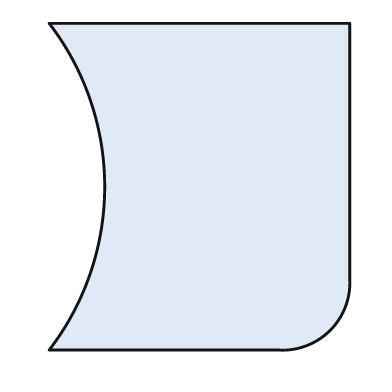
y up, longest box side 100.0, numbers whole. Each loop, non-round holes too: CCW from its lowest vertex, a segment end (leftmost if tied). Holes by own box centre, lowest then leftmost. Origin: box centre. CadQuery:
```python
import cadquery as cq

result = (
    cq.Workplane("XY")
    .moveTo(-46.0, -50.0)
    .lineTo(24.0, -50.0)
    .threePointArc((40.0, -44.0), (46.0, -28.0))
    .lineTo(46.0, 50.0)
    .lineTo(-46.0, 50.0)
    .threePointArc((-29.0, 0.0), (-46.0, -50.0))
    .close()
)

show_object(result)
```